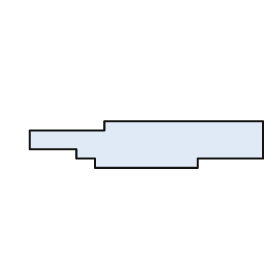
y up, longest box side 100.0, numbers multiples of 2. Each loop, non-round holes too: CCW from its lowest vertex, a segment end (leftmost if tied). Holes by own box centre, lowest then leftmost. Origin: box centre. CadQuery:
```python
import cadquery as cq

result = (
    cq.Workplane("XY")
    .moveTo(-22.0, -10.0)
    .lineTo(22.0, -10.0)
    .lineTo(22.0, -6.0)
    .lineTo(50.0, -6.0)
    .lineTo(50.0, 10.0)
    .lineTo(-18.0, 10.0)
    .lineTo(-18.0, 6.0)
    .lineTo(-50.0, 6.0)
    .lineTo(-50.0, -2.0)
    .lineTo(-30.0, -2.0)
    .lineTo(-30.0, -6.0)
    .lineTo(-22.0, -6.0)
    .close()
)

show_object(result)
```